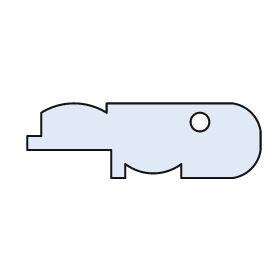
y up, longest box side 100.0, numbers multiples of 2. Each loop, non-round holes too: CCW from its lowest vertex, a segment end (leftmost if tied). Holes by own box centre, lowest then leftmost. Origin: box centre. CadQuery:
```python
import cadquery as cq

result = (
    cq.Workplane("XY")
    .moveTo(-14.0, -16.0)
    .lineTo(-8.0, -16.0)
    .lineTo(-8.0, -10.0)
    .threePointArc((4.0, -14.0), (16.0, -10.0))
    .lineTo(16.0, -16.0)
    .lineTo(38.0, -16.0)
    .threePointArc((46.0, -12.0), (50.0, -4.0))
    .lineTo(50.0, 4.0)
    .threePointArc((46.0, 12.0), (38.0, 16.0))
    .lineTo(-16.0, 16.0)
    .lineTo(-16.0, 12.0)
    .threePointArc((-30.0, 16.0), (-44.0, 12.0))
    .lineTo(-44.0, 2.0)
    .lineTo(-50.0, 2.0)
    .lineTo(-50.0, -4.0)
    .lineTo(-14.0, -4.0)
    .close()
    .moveTo(24.0, 8.0)
    .circle(4.0)
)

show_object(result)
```